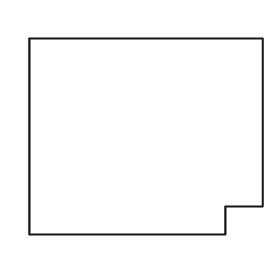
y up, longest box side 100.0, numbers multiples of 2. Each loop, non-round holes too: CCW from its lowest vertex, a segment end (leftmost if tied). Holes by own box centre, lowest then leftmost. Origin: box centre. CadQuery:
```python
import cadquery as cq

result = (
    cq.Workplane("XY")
    .moveTo(-50.0, -42.0)
    .lineTo(34.0, -42.0)
    .lineTo(34.0, -30.0)
    .lineTo(50.0, -30.0)
    .lineTo(50.0, 42.0)
    .lineTo(-50.0, 42.0)
    .close()
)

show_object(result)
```